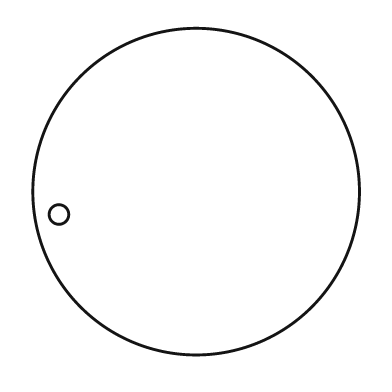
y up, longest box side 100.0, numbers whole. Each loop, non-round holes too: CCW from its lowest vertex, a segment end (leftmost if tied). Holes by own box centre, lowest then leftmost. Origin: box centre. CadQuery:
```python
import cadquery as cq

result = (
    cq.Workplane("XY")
    .moveTo(0.0, 0.0)
    .circle(50.0)
    .moveTo(-42.0, -7.0)
    .circle(3.0)
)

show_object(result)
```